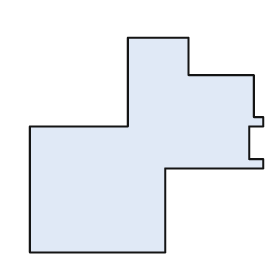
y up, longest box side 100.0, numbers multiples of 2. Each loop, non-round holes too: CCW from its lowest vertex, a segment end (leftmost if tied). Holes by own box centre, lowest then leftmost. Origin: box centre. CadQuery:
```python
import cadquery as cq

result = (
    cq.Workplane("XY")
    .moveTo(-50.0, -46.0)
    .lineTo(8.0, -46.0)
    .lineTo(8.0, -10.0)
    .lineTo(50.0, -10.0)
    .lineTo(50.0, -6.0)
    .lineTo(44.0, -6.0)
    .lineTo(44.0, 8.0)
    .lineTo(50.0, 8.0)
    .lineTo(50.0, 12.0)
    .lineTo(46.0, 12.0)
    .lineTo(46.0, 30.0)
    .lineTo(18.0, 30.0)
    .lineTo(18.0, 46.0)
    .lineTo(-8.0, 46.0)
    .lineTo(-8.0, 8.0)
    .lineTo(-50.0, 8.0)
    .close()
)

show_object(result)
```